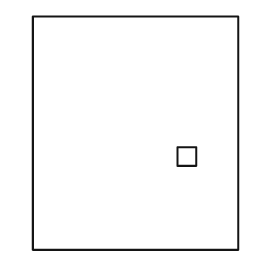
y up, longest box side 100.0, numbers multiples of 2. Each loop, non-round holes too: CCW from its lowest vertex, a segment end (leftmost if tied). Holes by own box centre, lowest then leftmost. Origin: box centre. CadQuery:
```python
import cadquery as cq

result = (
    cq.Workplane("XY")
    .moveTo(-44.0, -50.0)
    .lineTo(44.0, -50.0)
    .lineTo(44.0, 50.0)
    .lineTo(-44.0, 50.0)
    .close()
    .moveTo(18.0, -14.0)
    .lineTo(26.0, -14.0)
    .lineTo(26.0, -6.0)
    .lineTo(18.0, -6.0)
    .close()
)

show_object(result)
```